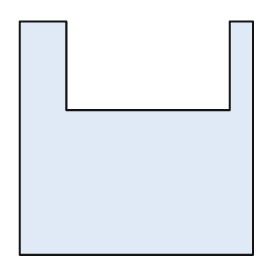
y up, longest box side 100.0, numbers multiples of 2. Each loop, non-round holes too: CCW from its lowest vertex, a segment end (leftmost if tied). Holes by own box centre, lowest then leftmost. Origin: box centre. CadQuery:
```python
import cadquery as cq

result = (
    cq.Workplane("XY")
    .moveTo(-50.0, -50.0)
    .lineTo(50.0, -50.0)
    .lineTo(50.0, 50.0)
    .lineTo(40.0, 50.0)
    .lineTo(40.0, 12.0)
    .lineTo(-30.0, 12.0)
    .lineTo(-30.0, 50.0)
    .lineTo(-50.0, 50.0)
    .close()
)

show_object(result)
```